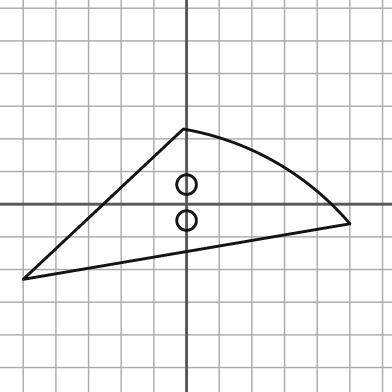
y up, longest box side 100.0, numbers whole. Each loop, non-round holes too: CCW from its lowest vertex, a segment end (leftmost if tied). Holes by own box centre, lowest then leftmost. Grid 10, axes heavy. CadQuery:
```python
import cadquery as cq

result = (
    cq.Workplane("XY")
    .moveTo(-50.0, -23.0)
    .lineTo(50.0, -6.0)
    .threePointArc((27.0, 13.0), (-1.0, 23.0))
    .close()
    .moveTo(0.0, -5.0)
    .circle(3.0)
    .moveTo(0.0, 6.0)
    .circle(3.0)
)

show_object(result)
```